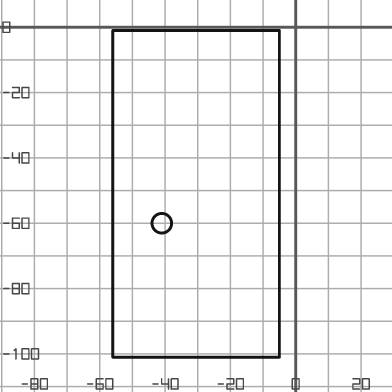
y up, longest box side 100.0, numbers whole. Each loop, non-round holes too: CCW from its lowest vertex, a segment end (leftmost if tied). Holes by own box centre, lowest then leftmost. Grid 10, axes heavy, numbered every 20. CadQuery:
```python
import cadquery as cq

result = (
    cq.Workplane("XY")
    .moveTo(-56.0, -101.0)
    .lineTo(-5.0, -101.0)
    .lineTo(-5.0, -1.0)
    .lineTo(-56.0, -1.0)
    .close()
    .moveTo(-41.0, -60.0)
    .circle(3.0)
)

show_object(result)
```